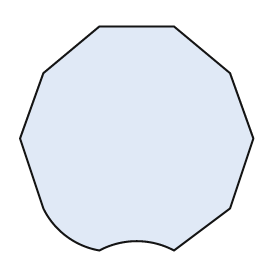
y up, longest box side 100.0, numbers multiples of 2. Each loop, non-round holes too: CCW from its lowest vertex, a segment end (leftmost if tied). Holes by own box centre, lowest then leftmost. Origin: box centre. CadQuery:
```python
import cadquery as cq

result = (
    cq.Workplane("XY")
    .moveTo(-16.0, -48.0)
    .threePointArc((0.0, -44.0), (16.0, -48.0))
    .lineTo(40.0, -30.0)
    .lineTo(50.0, 0.0)
    .lineTo(40.0, 28.0)
    .lineTo(16.0, 48.0)
    .lineTo(-16.0, 48.0)
    .lineTo(-40.0, 28.0)
    .lineTo(-50.0, 0.0)
    .lineTo(-40.0, -30.0)
    .threePointArc((-30.0, -42.0), (-16.0, -48.0))
    .close()
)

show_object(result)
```